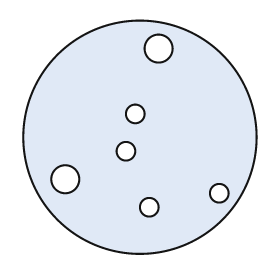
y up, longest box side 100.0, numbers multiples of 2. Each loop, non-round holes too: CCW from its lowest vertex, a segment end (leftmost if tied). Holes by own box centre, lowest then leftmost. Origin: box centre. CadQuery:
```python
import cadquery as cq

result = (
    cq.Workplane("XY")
    .moveTo(0.0, 0.0)
    .circle(50.0)
    .moveTo(4.0, -30.0)
    .circle(4.0)
    .moveTo(34.0, -24.0)
    .circle(4.0)
    .moveTo(-32.0, -18.0)
    .circle(6.0)
    .moveTo(-6.0, -6.0)
    .circle(4.0)
    .moveTo(-2.0, 10.0)
    .circle(4.0)
    .moveTo(8.0, 38.0)
    .circle(6.0)
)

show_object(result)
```